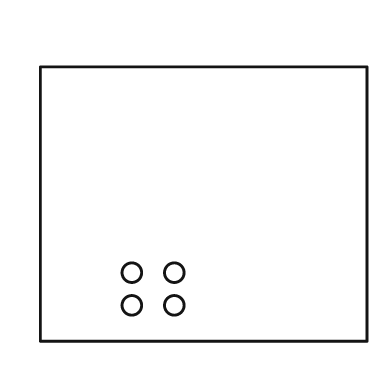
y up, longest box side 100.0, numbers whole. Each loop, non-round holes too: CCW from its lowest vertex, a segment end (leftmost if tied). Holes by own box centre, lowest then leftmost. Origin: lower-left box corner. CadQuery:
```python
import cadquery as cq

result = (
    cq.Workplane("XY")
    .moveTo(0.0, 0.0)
    .lineTo(100.0, 0.0)
    .lineTo(100.0, 84.0)
    .lineTo(0.0, 84.0)
    .close()
    .moveTo(28.0, 11.0)
    .circle(3.0)
    .moveTo(41.0, 11.0)
    .circle(3.0)
    .moveTo(28.0, 21.0)
    .circle(3.0)
    .moveTo(41.0, 21.0)
    .circle(3.0)
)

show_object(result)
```